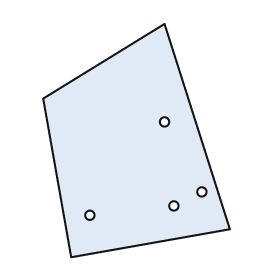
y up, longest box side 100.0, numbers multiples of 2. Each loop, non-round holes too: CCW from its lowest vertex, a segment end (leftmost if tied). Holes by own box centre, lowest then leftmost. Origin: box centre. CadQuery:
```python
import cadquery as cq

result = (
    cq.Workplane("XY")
    .moveTo(-28.0, -50.0)
    .lineTo(40.0, -38.0)
    .lineTo(12.0, 50.0)
    .lineTo(-40.0, 18.0)
    .close()
    .moveTo(-20.0, -32.0)
    .circle(2.0)
    .moveTo(16.0, -28.0)
    .circle(2.0)
    .moveTo(28.0, -22.0)
    .circle(2.0)
    .moveTo(12.0, 8.0)
    .circle(2.0)
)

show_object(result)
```